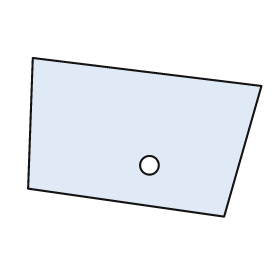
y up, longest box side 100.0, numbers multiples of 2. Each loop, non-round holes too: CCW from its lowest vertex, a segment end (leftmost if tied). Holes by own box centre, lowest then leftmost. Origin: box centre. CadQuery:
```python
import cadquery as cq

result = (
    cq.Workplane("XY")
    .moveTo(34.0, -34.0)
    .lineTo(50.0, 22.0)
    .lineTo(-48.0, 34.0)
    .lineTo(-50.0, -22.0)
    .close()
    .moveTo(2.0, -12.0)
    .circle(4.0)
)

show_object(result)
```